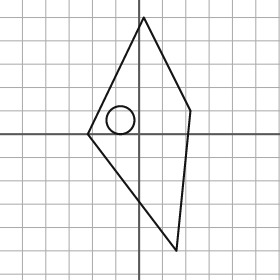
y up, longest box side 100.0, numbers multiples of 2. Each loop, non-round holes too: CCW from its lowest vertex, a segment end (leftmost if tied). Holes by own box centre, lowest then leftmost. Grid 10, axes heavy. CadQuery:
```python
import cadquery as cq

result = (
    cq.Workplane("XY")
    .moveTo(16.0, -50.0)
    .lineTo(22.0, 10.0)
    .lineTo(2.0, 50.0)
    .lineTo(-22.0, 0.0)
    .close()
    .moveTo(-8.0, 6.0)
    .circle(6.0)
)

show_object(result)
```